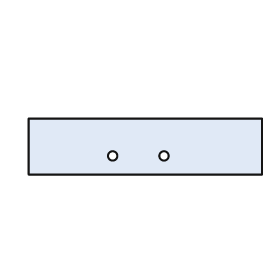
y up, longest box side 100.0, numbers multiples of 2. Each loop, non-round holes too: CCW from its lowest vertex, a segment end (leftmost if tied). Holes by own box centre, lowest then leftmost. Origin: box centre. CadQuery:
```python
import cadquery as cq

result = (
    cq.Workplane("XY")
    .moveTo(-50.0, -12.0)
    .lineTo(50.0, -12.0)
    .lineTo(50.0, 12.0)
    .lineTo(-50.0, 12.0)
    .close()
    .moveTo(-14.0, -4.0)
    .circle(2.0)
    .moveTo(8.0, -4.0)
    .circle(2.0)
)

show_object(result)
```